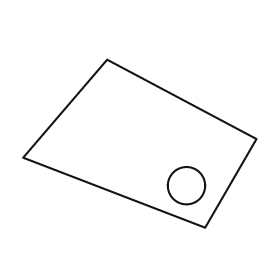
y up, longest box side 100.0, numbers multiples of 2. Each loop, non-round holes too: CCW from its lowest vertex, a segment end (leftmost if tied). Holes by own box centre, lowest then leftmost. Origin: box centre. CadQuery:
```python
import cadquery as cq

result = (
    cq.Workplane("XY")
    .moveTo(28.0, -36.0)
    .lineTo(50.0, 2.0)
    .lineTo(-14.0, 36.0)
    .lineTo(-50.0, -6.0)
    .close()
    .moveTo(20.0, -18.0)
    .circle(8.0)
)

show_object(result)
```